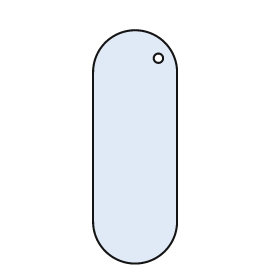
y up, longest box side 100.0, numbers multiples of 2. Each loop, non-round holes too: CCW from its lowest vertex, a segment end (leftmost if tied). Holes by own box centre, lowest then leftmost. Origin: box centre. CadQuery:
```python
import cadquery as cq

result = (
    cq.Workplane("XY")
    .moveTo(-18.0, -32.0)
    .threePointArc((0.0, -50.0), (18.0, -32.0))
    .lineTo(18.0, 32.0)
    .threePointArc((0.0, 50.0), (-18.0, 32.0))
    .close()
    .moveTo(10.0, 38.0)
    .circle(2.0)
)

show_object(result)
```